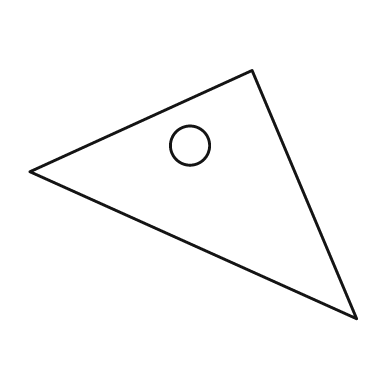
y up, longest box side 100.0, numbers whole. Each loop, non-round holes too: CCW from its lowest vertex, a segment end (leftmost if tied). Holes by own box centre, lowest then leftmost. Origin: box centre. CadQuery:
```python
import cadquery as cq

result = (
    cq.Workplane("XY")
    .moveTo(50.0, -38.0)
    .lineTo(18.0, 38.0)
    .lineTo(-50.0, 7.0)
    .close()
    .moveTo(-1.0, 15.0)
    .circle(6.0)
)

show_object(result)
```